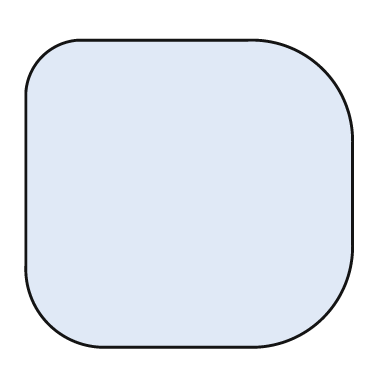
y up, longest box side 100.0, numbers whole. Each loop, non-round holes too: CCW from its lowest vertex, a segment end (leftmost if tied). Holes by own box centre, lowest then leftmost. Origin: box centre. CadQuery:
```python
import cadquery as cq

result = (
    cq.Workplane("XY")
    .moveTo(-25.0, -47.0)
    .lineTo(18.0, -47.0)
    .threePointArc((41.0, -38.0), (50.0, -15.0))
    .lineTo(50.0, 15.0)
    .threePointArc((41.0, 38.0), (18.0, 47.0))
    .lineTo(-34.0, 47.0)
    .threePointArc((-45.0, 42.0), (-50.0, 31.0))
    .lineTo(-50.0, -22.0)
    .threePointArc((-43.0, -40.0), (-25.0, -47.0))
    .close()
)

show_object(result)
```